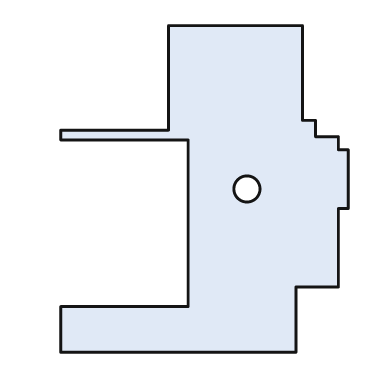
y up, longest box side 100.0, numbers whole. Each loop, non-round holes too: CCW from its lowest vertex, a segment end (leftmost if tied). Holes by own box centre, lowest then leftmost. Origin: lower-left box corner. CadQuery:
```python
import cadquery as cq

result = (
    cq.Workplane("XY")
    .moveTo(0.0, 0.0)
    .lineTo(72.0, 0.0)
    .lineTo(72.0, 20.0)
    .lineTo(85.0, 20.0)
    .lineTo(85.0, 44.0)
    .lineTo(88.0, 44.0)
    .lineTo(88.0, 62.0)
    .lineTo(85.0, 62.0)
    .lineTo(85.0, 66.0)
    .lineTo(78.0, 66.0)
    .lineTo(78.0, 71.0)
    .lineTo(74.0, 71.0)
    .lineTo(74.0, 100.0)
    .lineTo(33.0, 100.0)
    .lineTo(33.0, 68.0)
    .lineTo(0.0, 68.0)
    .lineTo(0.0, 65.0)
    .lineTo(39.0, 65.0)
    .lineTo(39.0, 14.0)
    .lineTo(0.0, 14.0)
    .close()
    .moveTo(57.0, 50.0)
    .circle(4.0)
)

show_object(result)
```